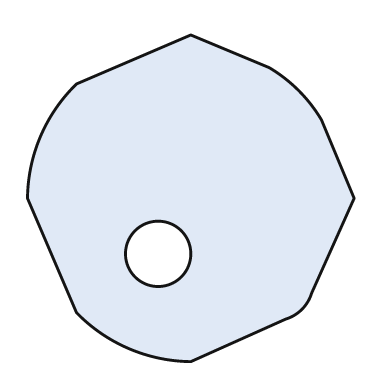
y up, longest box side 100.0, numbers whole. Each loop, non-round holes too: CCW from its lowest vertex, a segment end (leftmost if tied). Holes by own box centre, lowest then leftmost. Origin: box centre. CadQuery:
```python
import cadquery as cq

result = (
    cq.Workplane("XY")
    .moveTo(0.0, -50.0)
    .lineTo(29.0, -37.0)
    .threePointArc((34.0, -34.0), (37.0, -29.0))
    .lineTo(50.0, 0.0)
    .lineTo(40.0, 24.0)
    .threePointArc((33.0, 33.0), (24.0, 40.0))
    .lineTo(0.0, 50.0)
    .lineTo(-35.0, 35.0)
    .threePointArc((-46.0, 19.0), (-50.0, 0.0))
    .lineTo(-35.0, -35.0)
    .threePointArc((-19.0, -46.0), (0.0, -50.0))
    .close()
    .moveTo(-10.0, -17.0)
    .circle(10.0)
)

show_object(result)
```